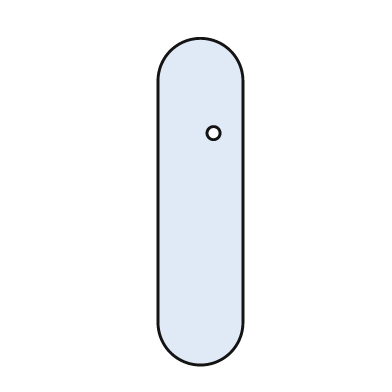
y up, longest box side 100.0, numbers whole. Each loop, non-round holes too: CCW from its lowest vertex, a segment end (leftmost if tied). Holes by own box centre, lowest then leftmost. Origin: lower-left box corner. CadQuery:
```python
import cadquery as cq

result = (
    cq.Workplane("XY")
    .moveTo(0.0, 13.0)
    .threePointArc((13.0, 0.0), (26.0, 13.0))
    .lineTo(26.0, 87.0)
    .threePointArc((13.0, 100.0), (0.0, 87.0))
    .close()
    .moveTo(17.0, 71.0)
    .circle(2.0)
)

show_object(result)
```